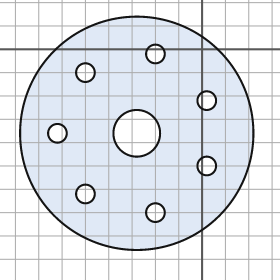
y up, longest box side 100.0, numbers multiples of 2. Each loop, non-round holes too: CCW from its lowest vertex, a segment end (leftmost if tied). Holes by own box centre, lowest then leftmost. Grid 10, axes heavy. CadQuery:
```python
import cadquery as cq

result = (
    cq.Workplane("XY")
    .moveTo(-28.0, -36.0)
    .circle(50.0)
    .moveTo(-20.0, -70.0)
    .circle(4.0)
    .moveTo(-50.0, -62.0)
    .circle(4.0)
    .moveTo(2.0, -50.0)
    .circle(4.0)
    .moveTo(-62.0, -36.0)
    .circle(4.0)
    .moveTo(-28.0, -36.0)
    .circle(10.0)
    .moveTo(2.0, -22.0)
    .circle(4.0)
    .moveTo(-50.0, -10.0)
    .circle(4.0)
    .moveTo(-20.0, -2.0)
    .circle(4.0)
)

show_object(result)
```